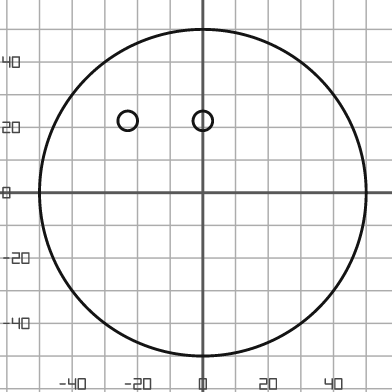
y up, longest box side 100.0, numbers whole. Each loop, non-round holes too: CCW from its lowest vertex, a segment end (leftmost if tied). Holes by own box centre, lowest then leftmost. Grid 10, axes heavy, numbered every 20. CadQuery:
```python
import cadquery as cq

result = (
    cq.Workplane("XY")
    .moveTo(0.0, 0.0)
    .circle(50.0)
    .moveTo(-23.0, 22.0)
    .circle(3.0)
    .moveTo(0.0, 22.0)
    .circle(3.0)
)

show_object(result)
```